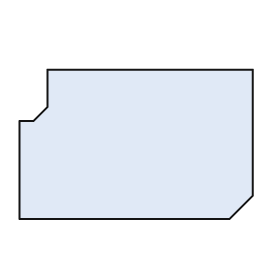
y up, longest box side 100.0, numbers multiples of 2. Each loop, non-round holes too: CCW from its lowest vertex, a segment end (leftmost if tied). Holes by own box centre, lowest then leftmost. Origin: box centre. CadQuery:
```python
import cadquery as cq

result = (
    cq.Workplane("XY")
    .moveTo(-50.0, -32.0)
    .lineTo(40.0, -32.0)
    .lineTo(50.0, -22.0)
    .lineTo(50.0, 32.0)
    .lineTo(-38.0, 32.0)
    .lineTo(-38.0, 16.0)
    .lineTo(-44.0, 10.0)
    .lineTo(-50.0, 10.0)
    .close()
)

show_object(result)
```